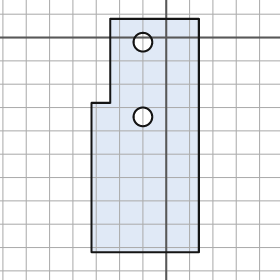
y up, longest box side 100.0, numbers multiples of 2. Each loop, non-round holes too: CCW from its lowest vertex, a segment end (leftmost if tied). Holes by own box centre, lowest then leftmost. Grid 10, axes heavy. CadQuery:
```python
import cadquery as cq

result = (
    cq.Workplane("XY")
    .moveTo(-32.0, -92.0)
    .lineTo(14.0, -92.0)
    .lineTo(14.0, 8.0)
    .lineTo(-24.0, 8.0)
    .lineTo(-24.0, -28.0)
    .lineTo(-32.0, -28.0)
    .close()
    .moveTo(-10.0, -34.0)
    .circle(4.0)
    .moveTo(-10.0, -2.0)
    .circle(4.0)
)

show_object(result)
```